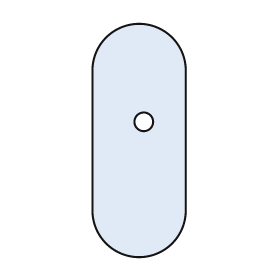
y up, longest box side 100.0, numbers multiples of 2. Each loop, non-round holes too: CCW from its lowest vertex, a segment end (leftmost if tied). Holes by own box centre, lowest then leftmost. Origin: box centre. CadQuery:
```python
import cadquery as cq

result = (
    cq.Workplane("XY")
    .moveTo(-20.0, -30.0)
    .threePointArc((0.0, -50.0), (20.0, -30.0))
    .lineTo(20.0, 30.0)
    .threePointArc((0.0, 50.0), (-20.0, 30.0))
    .close()
    .moveTo(2.0, 8.0)
    .circle(4.0)
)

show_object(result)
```